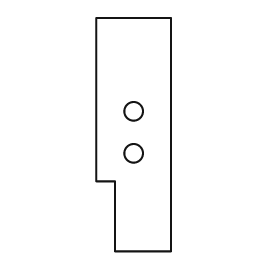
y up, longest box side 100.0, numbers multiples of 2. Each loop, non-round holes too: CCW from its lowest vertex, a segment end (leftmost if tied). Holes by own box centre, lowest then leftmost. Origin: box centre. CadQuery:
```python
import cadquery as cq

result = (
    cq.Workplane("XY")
    .moveTo(-8.0, -50.0)
    .lineTo(16.0, -50.0)
    .lineTo(16.0, 50.0)
    .lineTo(-16.0, 50.0)
    .lineTo(-16.0, -20.0)
    .lineTo(-8.0, -20.0)
    .close()
    .moveTo(0.0, -8.0)
    .circle(4.0)
    .moveTo(0.0, 10.0)
    .circle(4.0)
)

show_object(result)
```